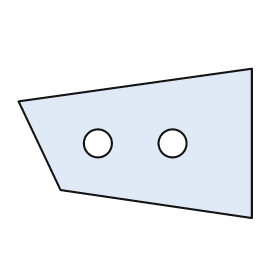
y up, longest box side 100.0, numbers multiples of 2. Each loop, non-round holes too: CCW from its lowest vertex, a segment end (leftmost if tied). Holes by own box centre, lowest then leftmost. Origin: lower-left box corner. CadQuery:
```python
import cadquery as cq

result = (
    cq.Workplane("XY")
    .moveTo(100.0, 0.0)
    .lineTo(100.0, 64.0)
    .lineTo(0.0, 50.0)
    .lineTo(18.0, 12.0)
    .close()
    .moveTo(34.0, 32.0)
    .circle(6.0)
    .moveTo(66.0, 32.0)
    .circle(6.0)
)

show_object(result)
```